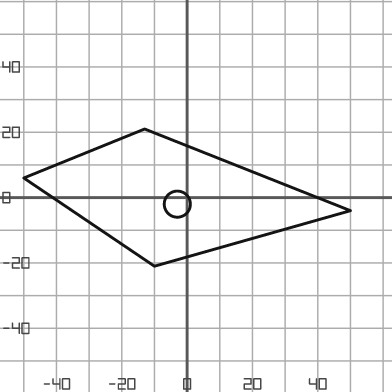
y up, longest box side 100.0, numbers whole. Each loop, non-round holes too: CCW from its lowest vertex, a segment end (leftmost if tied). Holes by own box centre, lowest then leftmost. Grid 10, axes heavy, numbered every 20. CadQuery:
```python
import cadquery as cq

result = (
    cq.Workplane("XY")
    .moveTo(-10.0, -21.0)
    .lineTo(50.0, -4.0)
    .lineTo(-13.0, 21.0)
    .lineTo(-50.0, 6.0)
    .close()
    .moveTo(-3.0, -2.0)
    .circle(4.0)
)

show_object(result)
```